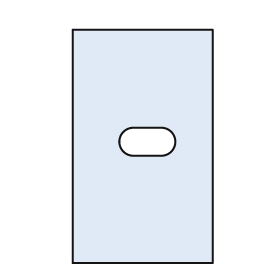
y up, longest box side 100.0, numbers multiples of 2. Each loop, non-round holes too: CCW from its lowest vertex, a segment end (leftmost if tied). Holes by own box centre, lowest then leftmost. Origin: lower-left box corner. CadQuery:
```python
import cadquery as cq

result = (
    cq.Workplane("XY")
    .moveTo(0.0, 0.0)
    .lineTo(60.0, 0.0)
    .lineTo(60.0, 100.0)
    .lineTo(0.0, 100.0)
    .close()
    .moveTo(26.0, 46.0)
    .lineTo(38.0, 46.0)
    .threePointArc((44.0, 52.0), (38.0, 58.0))
    .lineTo(26.0, 58.0)
    .threePointArc((20.0, 52.0), (26.0, 46.0))
    .close()
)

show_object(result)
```